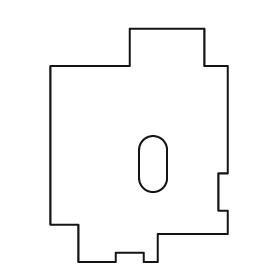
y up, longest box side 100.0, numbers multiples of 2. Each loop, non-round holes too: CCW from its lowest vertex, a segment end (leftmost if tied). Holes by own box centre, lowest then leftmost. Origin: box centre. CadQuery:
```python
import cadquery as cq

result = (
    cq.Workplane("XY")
    .moveTo(-26.0, -50.0)
    .lineTo(-10.0, -50.0)
    .lineTo(-10.0, -46.0)
    .lineTo(2.0, -46.0)
    .lineTo(2.0, -50.0)
    .lineTo(8.0, -50.0)
    .lineTo(8.0, -38.0)
    .lineTo(38.0, -38.0)
    .lineTo(38.0, -28.0)
    .lineTo(34.0, -28.0)
    .lineTo(34.0, -12.0)
    .lineTo(38.0, -12.0)
    .lineTo(38.0, 34.0)
    .lineTo(28.0, 34.0)
    .lineTo(28.0, 50.0)
    .lineTo(-4.0, 50.0)
    .lineTo(-4.0, 34.0)
    .lineTo(-38.0, 34.0)
    .lineTo(-38.0, -34.0)
    .lineTo(-26.0, -34.0)
    .close()
    .moveTo(0.0, -14.0)
    .threePointArc((6.0, -20.0), (12.0, -14.0))
    .lineTo(12.0, -2.0)
    .threePointArc((6.0, 4.0), (0.0, -2.0))
    .close()
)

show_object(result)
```